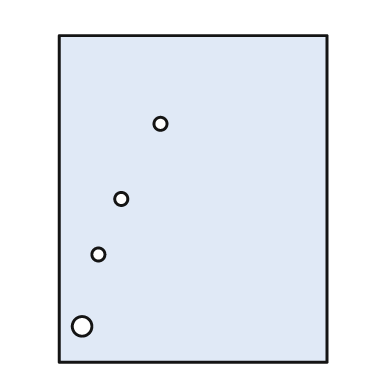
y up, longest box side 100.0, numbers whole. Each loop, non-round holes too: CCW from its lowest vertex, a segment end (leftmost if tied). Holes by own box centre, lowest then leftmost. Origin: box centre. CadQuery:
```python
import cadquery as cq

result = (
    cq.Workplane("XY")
    .moveTo(-41.0, -50.0)
    .lineTo(41.0, -50.0)
    .lineTo(41.0, 50.0)
    .lineTo(-41.0, 50.0)
    .close()
    .moveTo(-34.0, -39.0)
    .circle(3.0)
    .moveTo(-29.0, -17.0)
    .circle(2.0)
    .moveTo(-22.0, 0.0)
    .circle(2.0)
    .moveTo(-10.0, 23.0)
    .circle(2.0)
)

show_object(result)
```